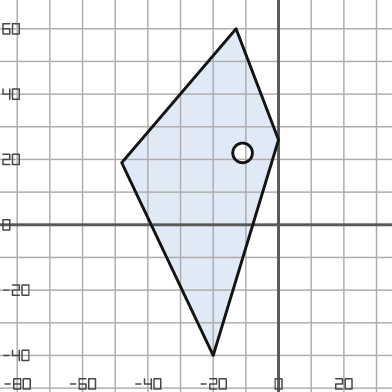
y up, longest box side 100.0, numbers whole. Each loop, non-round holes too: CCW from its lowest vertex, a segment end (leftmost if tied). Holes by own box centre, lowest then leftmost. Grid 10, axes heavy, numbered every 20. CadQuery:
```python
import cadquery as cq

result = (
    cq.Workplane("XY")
    .moveTo(-20.0, -40.0)
    .lineTo(0.0, 26.0)
    .lineTo(-13.0, 60.0)
    .lineTo(-48.0, 19.0)
    .close()
    .moveTo(-11.0, 22.0)
    .circle(3.0)
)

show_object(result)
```